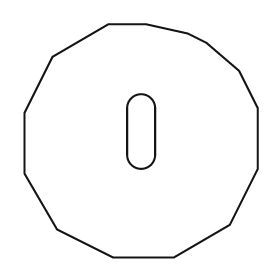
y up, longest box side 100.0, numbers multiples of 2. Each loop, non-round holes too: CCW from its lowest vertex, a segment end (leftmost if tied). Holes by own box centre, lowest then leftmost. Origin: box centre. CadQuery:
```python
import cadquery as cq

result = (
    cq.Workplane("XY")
    .moveTo(-12.0, -50.0)
    .lineTo(14.0, -50.0)
    .lineTo(38.0, -36.0)
    .lineTo(50.0, -12.0)
    .lineTo(50.0, 14.0)
    .lineTo(42.0, 30.0)
    .lineTo(28.0, 42.0)
    .lineTo(20.0, 46.0)
    .lineTo(2.0, 50.0)
    .lineTo(-14.0, 50.0)
    .lineTo(-38.0, 36.0)
    .lineTo(-50.0, 12.0)
    .lineTo(-50.0, -14.0)
    .lineTo(-36.0, -38.0)
    .close()
    .moveTo(-6.0, -6.0)
    .threePointArc((0.0, -12.0), (6.0, -6.0))
    .lineTo(6.0, 14.0)
    .threePointArc((0.0, 20.0), (-6.0, 14.0))
    .close()
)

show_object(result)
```